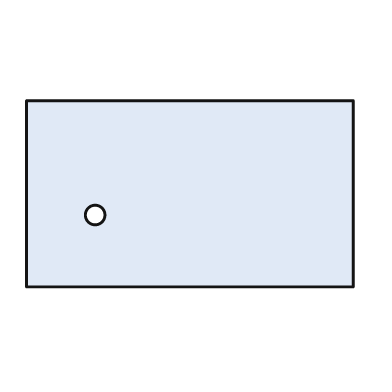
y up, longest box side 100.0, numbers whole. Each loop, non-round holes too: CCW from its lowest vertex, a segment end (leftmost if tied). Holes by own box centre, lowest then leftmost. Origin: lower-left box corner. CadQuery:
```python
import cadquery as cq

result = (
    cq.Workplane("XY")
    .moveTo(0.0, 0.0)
    .lineTo(100.0, 0.0)
    .lineTo(100.0, 57.0)
    .lineTo(0.0, 57.0)
    .close()
    .moveTo(21.0, 22.0)
    .circle(3.0)
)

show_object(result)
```